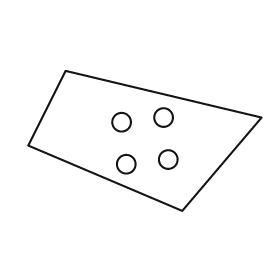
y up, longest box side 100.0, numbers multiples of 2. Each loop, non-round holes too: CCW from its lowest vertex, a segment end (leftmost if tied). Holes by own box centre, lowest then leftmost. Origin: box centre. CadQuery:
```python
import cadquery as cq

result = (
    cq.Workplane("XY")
    .moveTo(16.0, -30.0)
    .lineTo(50.0, 10.0)
    .lineTo(-34.0, 30.0)
    .lineTo(-50.0, -2.0)
    .close()
    .moveTo(-8.0, -10.0)
    .circle(4.0)
    .moveTo(10.0, -8.0)
    .circle(4.0)
    .moveTo(-10.0, 8.0)
    .circle(4.0)
    .moveTo(8.0, 10.0)
    .circle(4.0)
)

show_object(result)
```